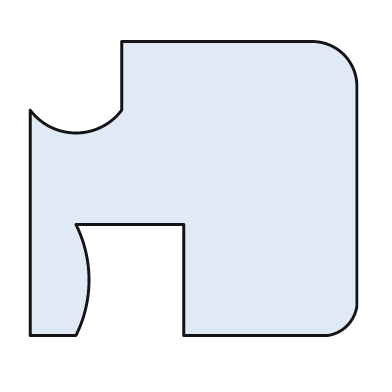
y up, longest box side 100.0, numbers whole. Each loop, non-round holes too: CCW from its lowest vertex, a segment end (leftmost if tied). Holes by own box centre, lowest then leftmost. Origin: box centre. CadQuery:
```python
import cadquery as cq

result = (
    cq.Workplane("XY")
    .moveTo(-50.0, -45.0)
    .lineTo(-36.0, -45.0)
    .threePointArc((-32.0, -28.0), (-36.0, -11.0))
    .lineTo(-3.0, -11.0)
    .lineTo(-3.0, -45.0)
    .lineTo(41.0, -45.0)
    .threePointArc((47.0, -42.0), (50.0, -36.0))
    .lineTo(50.0, 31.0)
    .threePointArc((46.0, 41.0), (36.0, 45.0))
    .lineTo(-22.0, 45.0)
    .lineTo(-22.0, 24.0)
    .threePointArc((-36.0, 17.0), (-50.0, 24.0))
    .close()
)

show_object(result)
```